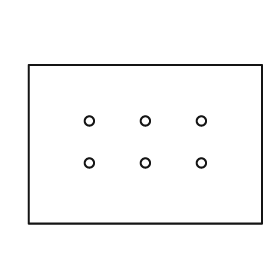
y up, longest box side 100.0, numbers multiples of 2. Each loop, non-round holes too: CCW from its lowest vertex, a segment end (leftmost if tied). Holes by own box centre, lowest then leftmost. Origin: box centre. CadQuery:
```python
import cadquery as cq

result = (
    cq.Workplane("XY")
    .moveTo(-50.0, -34.0)
    .lineTo(50.0, -34.0)
    .lineTo(50.0, 34.0)
    .lineTo(-50.0, 34.0)
    .close()
    .moveTo(-24.0, -8.0)
    .circle(2.0)
    .moveTo(0.0, -8.0)
    .circle(2.0)
    .moveTo(24.0, -8.0)
    .circle(2.0)
    .moveTo(-24.0, 10.0)
    .circle(2.0)
    .moveTo(0.0, 10.0)
    .circle(2.0)
    .moveTo(24.0, 10.0)
    .circle(2.0)
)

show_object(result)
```